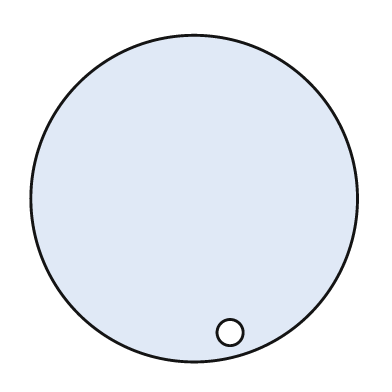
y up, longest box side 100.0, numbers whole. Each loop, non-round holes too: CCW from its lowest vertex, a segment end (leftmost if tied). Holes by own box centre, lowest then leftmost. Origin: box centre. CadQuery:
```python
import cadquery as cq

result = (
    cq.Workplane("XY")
    .moveTo(0.0, 0.0)
    .circle(50.0)
    .moveTo(11.0, -41.0)
    .circle(4.0)
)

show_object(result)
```